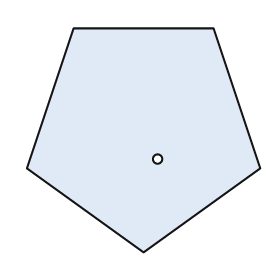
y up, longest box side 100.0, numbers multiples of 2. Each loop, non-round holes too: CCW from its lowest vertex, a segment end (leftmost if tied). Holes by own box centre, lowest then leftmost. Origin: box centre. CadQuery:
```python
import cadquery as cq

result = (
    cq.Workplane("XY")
    .moveTo(0.0, -48.0)
    .lineTo(50.0, -12.0)
    .lineTo(30.0, 48.0)
    .lineTo(-30.0, 48.0)
    .lineTo(-50.0, -12.0)
    .close()
    .moveTo(6.0, -8.0)
    .circle(2.0)
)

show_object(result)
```